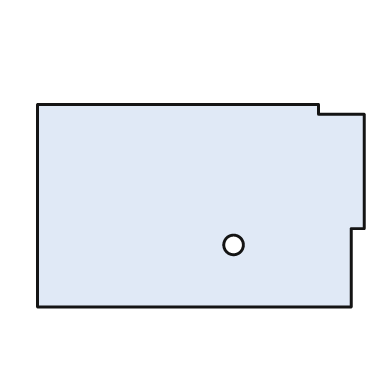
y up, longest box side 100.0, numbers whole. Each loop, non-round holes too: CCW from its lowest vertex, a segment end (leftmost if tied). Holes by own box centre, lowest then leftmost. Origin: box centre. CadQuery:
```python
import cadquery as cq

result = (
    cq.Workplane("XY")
    .moveTo(-50.0, -31.0)
    .lineTo(46.0, -31.0)
    .lineTo(46.0, -7.0)
    .lineTo(50.0, -7.0)
    .lineTo(50.0, 28.0)
    .lineTo(36.0, 28.0)
    .lineTo(36.0, 31.0)
    .lineTo(-50.0, 31.0)
    .close()
    .moveTo(10.0, -12.0)
    .circle(3.0)
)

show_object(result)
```